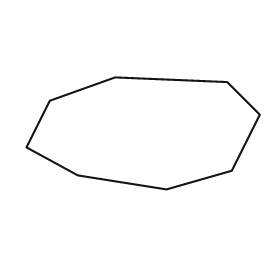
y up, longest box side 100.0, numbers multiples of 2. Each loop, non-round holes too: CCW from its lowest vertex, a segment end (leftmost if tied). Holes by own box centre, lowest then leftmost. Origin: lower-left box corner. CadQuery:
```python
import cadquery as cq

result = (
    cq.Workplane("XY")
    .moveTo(60.0, 0.0)
    .lineTo(88.0, 8.0)
    .lineTo(100.0, 32.0)
    .lineTo(86.0, 46.0)
    .lineTo(38.0, 48.0)
    .lineTo(10.0, 38.0)
    .lineTo(0.0, 18.0)
    .lineTo(22.0, 6.0)
    .close()
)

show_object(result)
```